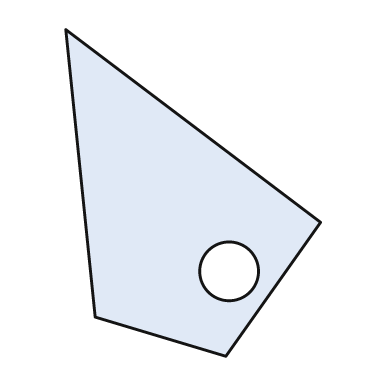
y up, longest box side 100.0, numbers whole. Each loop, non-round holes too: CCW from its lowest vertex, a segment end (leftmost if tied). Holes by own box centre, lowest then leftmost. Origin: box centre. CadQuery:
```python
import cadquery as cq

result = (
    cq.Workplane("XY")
    .moveTo(10.0, -50.0)
    .lineTo(39.0, -9.0)
    .lineTo(-39.0, 50.0)
    .lineTo(-30.0, -38.0)
    .close()
    .moveTo(11.0, -24.0)
    .circle(9.0)
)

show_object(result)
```